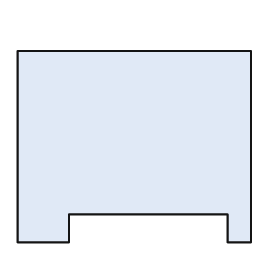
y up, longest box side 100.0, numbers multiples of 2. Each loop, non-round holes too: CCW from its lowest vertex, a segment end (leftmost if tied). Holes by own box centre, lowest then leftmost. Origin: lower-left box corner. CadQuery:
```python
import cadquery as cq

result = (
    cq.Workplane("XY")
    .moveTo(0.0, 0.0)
    .lineTo(22.0, 0.0)
    .lineTo(22.0, 12.0)
    .lineTo(90.0, 12.0)
    .lineTo(90.0, 0.0)
    .lineTo(100.0, 0.0)
    .lineTo(100.0, 82.0)
    .lineTo(0.0, 82.0)
    .close()
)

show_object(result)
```